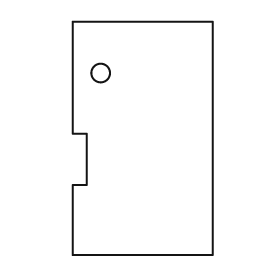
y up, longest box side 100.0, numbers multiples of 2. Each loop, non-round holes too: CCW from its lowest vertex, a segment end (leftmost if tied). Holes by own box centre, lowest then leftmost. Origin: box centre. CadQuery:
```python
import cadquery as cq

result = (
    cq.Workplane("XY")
    .moveTo(-30.0, -50.0)
    .lineTo(30.0, -50.0)
    .lineTo(30.0, 50.0)
    .lineTo(-30.0, 50.0)
    .lineTo(-30.0, 2.0)
    .lineTo(-24.0, 2.0)
    .lineTo(-24.0, -20.0)
    .lineTo(-30.0, -20.0)
    .close()
    .moveTo(-18.0, 28.0)
    .circle(4.0)
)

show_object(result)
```